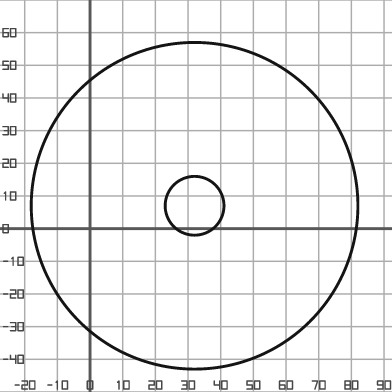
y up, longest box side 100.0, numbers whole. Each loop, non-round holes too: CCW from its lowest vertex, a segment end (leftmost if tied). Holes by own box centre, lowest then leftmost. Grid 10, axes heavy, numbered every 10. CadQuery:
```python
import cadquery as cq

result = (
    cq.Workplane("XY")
    .moveTo(32.0, 7.0)
    .circle(50.0)
    .moveTo(32.0, 7.0)
    .circle(9.0)
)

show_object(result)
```